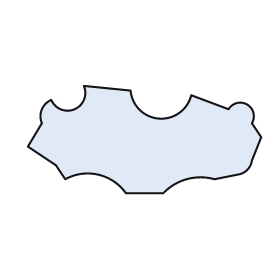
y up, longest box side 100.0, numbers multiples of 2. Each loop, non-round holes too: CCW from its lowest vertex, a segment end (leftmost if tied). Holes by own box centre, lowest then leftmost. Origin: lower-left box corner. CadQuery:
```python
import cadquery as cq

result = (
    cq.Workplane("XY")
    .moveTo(42.0, 0.0)
    .lineTo(58.0, 0.0)
    .threePointArc((68.0, 6.0), (80.0, 6.0))
    .lineTo(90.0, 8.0)
    .threePointArc((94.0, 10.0), (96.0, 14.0))
    .lineTo(100.0, 24.0)
    .lineTo(96.0, 30.0)
    .threePointArc((94.0, 38.0), (86.0, 36.0))
    .lineTo(70.0, 42.0)
    .threePointArc((56.0, 32.0), (44.0, 44.0))
    .lineTo(24.0, 46.0)
    .threePointArc((20.0, 36.0), (10.0, 40.0))
    .threePointArc((6.0, 36.0), (6.0, 30.0))
    .lineTo(0.0, 20.0)
    .lineTo(12.0, 12.0)
    .lineTo(16.0, 6.0)
    .threePointArc((30.0, 8.0), (42.0, 0.0))
    .close()
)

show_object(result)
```